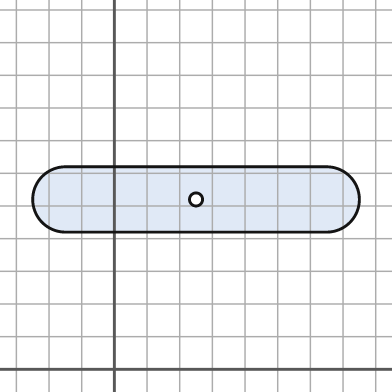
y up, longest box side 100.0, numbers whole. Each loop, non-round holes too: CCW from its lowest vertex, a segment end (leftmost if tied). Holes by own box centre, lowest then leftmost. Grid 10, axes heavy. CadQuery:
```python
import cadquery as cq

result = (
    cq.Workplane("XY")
    .moveTo(-15.0, 42.0)
    .lineTo(65.0, 42.0)
    .threePointArc((75.0, 52.0), (65.0, 62.0))
    .lineTo(-15.0, 62.0)
    .threePointArc((-25.0, 52.0), (-15.0, 42.0))
    .close()
    .moveTo(25.0, 52.0)
    .circle(2.0)
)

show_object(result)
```